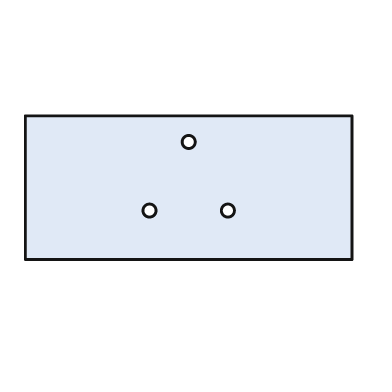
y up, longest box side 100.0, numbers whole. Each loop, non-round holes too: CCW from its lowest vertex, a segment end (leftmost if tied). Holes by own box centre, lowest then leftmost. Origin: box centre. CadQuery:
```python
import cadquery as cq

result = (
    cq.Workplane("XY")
    .moveTo(-50.0, -22.0)
    .lineTo(50.0, -22.0)
    .lineTo(50.0, 22.0)
    .lineTo(-50.0, 22.0)
    .close()
    .moveTo(-12.0, -7.0)
    .circle(2.0)
    .moveTo(12.0, -7.0)
    .circle(2.0)
    .moveTo(0.0, 14.0)
    .circle(2.0)
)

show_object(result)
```